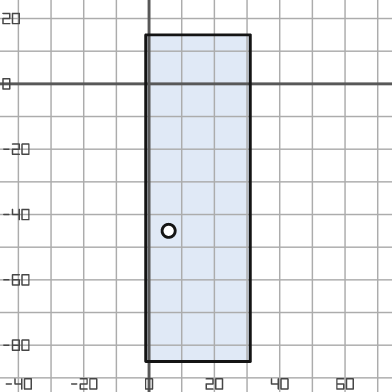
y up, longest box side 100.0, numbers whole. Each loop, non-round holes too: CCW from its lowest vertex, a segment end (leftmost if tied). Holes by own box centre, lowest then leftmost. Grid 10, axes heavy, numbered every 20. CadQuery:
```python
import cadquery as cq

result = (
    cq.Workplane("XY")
    .moveTo(-1.0, -85.0)
    .lineTo(31.0, -85.0)
    .lineTo(31.0, 15.0)
    .lineTo(-1.0, 15.0)
    .close()
    .moveTo(6.0, -45.0)
    .circle(2.0)
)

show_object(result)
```